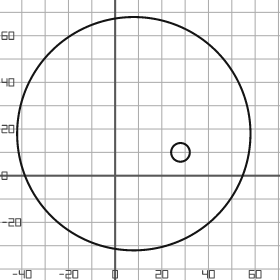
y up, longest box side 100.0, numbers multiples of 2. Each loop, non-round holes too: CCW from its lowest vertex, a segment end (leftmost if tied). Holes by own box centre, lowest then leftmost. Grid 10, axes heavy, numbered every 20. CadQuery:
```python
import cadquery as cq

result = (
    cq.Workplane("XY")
    .moveTo(8.0, 18.0)
    .circle(50.0)
    .moveTo(28.0, 10.0)
    .circle(4.0)
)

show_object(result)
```